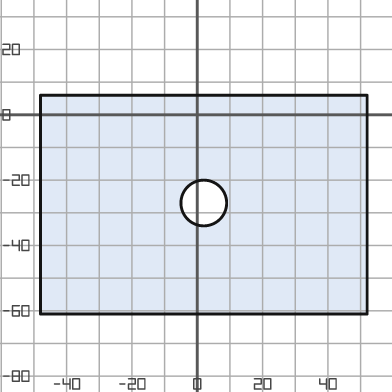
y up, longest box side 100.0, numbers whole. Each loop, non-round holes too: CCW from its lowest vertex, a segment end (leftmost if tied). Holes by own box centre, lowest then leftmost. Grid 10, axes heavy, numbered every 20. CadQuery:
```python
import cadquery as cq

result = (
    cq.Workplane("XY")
    .moveTo(-48.0, -61.0)
    .lineTo(52.0, -61.0)
    .lineTo(52.0, 6.0)
    .lineTo(-48.0, 6.0)
    .close()
    .moveTo(2.0, -27.0)
    .circle(7.0)
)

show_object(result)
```